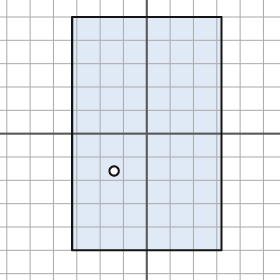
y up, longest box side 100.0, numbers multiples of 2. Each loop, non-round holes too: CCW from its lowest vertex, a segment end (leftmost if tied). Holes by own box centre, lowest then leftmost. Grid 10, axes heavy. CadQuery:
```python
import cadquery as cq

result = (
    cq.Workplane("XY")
    .moveTo(-32.0, -50.0)
    .lineTo(32.0, -50.0)
    .lineTo(32.0, 50.0)
    .lineTo(-32.0, 50.0)
    .close()
    .moveTo(-14.0, -16.0)
    .circle(2.0)
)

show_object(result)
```